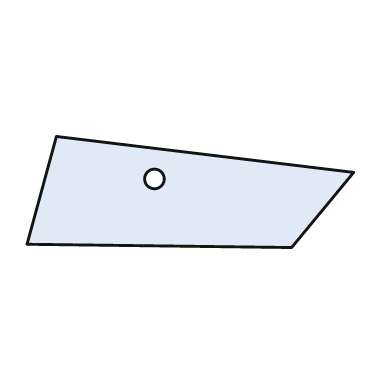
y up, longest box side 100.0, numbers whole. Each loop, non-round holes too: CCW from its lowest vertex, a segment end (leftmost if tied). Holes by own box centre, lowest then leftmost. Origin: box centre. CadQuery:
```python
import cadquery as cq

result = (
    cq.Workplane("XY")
    .moveTo(31.0, -17.0)
    .lineTo(50.0, 6.0)
    .lineTo(-41.0, 17.0)
    .lineTo(-50.0, -16.0)
    .close()
    .moveTo(-11.0, 4.0)
    .circle(3.0)
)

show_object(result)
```